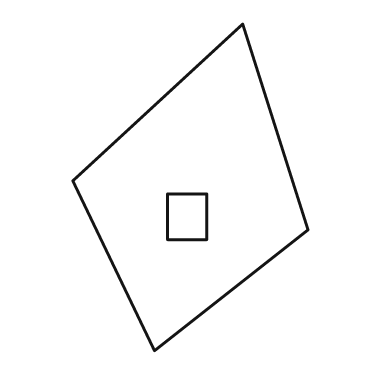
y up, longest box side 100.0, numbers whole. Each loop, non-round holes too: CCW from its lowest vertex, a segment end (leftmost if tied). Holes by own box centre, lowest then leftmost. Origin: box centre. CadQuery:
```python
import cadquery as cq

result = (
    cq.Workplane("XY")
    .moveTo(-11.0, -50.0)
    .lineTo(36.0, -13.0)
    .lineTo(16.0, 50.0)
    .lineTo(-36.0, 2.0)
    .close()
    .moveTo(-7.0, -16.0)
    .lineTo(5.0, -16.0)
    .lineTo(5.0, -2.0)
    .lineTo(-7.0, -2.0)
    .close()
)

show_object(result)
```